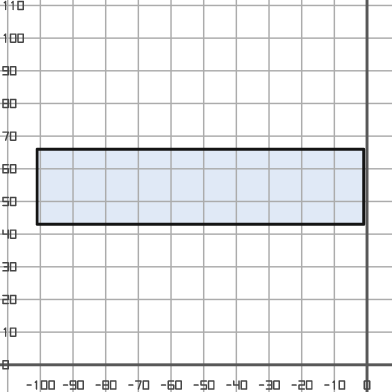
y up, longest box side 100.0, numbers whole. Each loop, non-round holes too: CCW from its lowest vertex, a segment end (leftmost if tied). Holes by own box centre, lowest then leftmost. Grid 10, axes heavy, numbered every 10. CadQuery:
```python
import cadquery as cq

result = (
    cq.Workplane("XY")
    .moveTo(-101.0, 43.0)
    .lineTo(-1.0, 43.0)
    .lineTo(-1.0, 66.0)
    .lineTo(-101.0, 66.0)
    .close()
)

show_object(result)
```